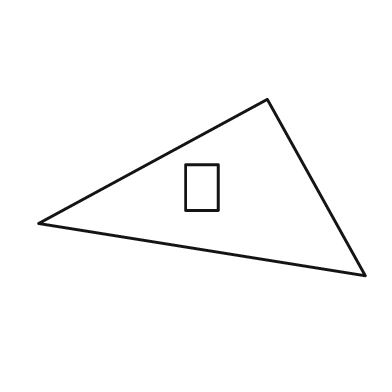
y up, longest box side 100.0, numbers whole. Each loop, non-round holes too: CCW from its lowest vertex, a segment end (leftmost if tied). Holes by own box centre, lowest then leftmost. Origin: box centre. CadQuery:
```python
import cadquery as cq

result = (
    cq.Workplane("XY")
    .moveTo(50.0, -27.0)
    .lineTo(20.0, 27.0)
    .lineTo(-50.0, -11.0)
    .close()
    .moveTo(-5.0, -7.0)
    .lineTo(5.0, -7.0)
    .lineTo(5.0, 7.0)
    .lineTo(-5.0, 7.0)
    .close()
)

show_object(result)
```